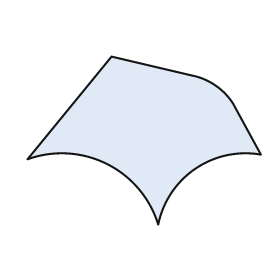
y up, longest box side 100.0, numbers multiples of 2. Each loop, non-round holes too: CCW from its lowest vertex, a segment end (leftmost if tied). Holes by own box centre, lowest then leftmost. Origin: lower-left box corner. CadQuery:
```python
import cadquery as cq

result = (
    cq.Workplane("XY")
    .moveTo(56.0, 0.0)
    .threePointArc((72.0, 24.0), (100.0, 30.0))
    .lineTo(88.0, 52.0)
    .threePointArc((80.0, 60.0), (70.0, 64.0))
    .lineTo(36.0, 72.0)
    .lineTo(0.0, 28.0)
    .threePointArc((34.0, 26.0), (56.0, 0.0))
    .close()
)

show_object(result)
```